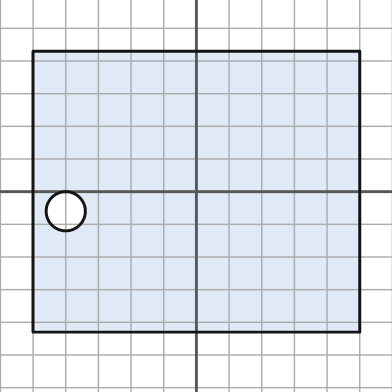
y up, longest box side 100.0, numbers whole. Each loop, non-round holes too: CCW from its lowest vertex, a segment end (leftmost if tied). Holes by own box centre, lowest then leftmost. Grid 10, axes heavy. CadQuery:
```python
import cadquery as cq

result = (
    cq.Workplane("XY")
    .moveTo(-50.0, -43.0)
    .lineTo(50.0, -43.0)
    .lineTo(50.0, 43.0)
    .lineTo(-50.0, 43.0)
    .close()
    .moveTo(-40.0, -6.0)
    .circle(6.0)
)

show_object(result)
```